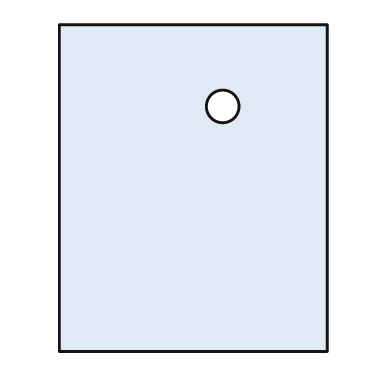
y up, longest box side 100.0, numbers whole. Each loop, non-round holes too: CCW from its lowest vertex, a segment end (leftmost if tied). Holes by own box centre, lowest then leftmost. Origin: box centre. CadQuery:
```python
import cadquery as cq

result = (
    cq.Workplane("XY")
    .moveTo(-41.0, -50.0)
    .lineTo(41.0, -50.0)
    .lineTo(41.0, 50.0)
    .lineTo(-41.0, 50.0)
    .close()
    .moveTo(9.0, 25.0)
    .circle(5.0)
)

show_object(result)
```